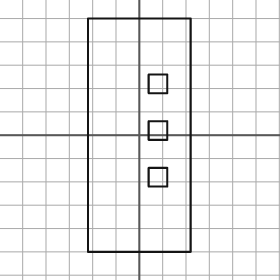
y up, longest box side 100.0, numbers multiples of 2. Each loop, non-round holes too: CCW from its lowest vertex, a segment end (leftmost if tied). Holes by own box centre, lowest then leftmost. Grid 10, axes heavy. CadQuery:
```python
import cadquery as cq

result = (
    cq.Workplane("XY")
    .moveTo(-22.0, -50.0)
    .lineTo(22.0, -50.0)
    .lineTo(22.0, 50.0)
    .lineTo(-22.0, 50.0)
    .close()
    .moveTo(4.0, -22.0)
    .lineTo(12.0, -22.0)
    .lineTo(12.0, -14.0)
    .lineTo(4.0, -14.0)
    .close()
    .moveTo(4.0, -2.0)
    .lineTo(12.0, -2.0)
    .lineTo(12.0, 6.0)
    .lineTo(4.0, 6.0)
    .close()
    .moveTo(4.0, 18.0)
    .lineTo(12.0, 18.0)
    .lineTo(12.0, 26.0)
    .lineTo(4.0, 26.0)
    .close()
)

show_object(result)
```